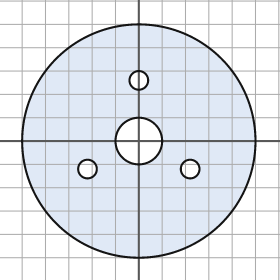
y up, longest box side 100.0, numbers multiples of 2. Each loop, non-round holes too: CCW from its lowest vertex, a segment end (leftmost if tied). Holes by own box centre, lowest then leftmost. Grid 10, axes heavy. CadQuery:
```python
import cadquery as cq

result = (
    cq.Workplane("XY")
    .moveTo(0.0, 0.0)
    .circle(50.0)
    .moveTo(-22.0, -12.0)
    .circle(4.0)
    .moveTo(22.0, -12.0)
    .circle(4.0)
    .moveTo(0.0, 0.0)
    .circle(10.0)
    .moveTo(0.0, 26.0)
    .circle(4.0)
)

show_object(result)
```